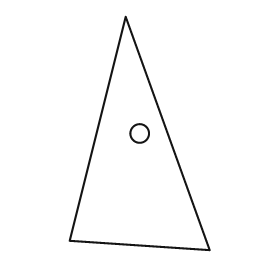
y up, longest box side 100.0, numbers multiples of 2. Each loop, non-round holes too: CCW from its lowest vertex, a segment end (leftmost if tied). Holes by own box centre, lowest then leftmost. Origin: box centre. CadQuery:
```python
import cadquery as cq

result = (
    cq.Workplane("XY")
    .moveTo(30.0, -50.0)
    .lineTo(-6.0, 50.0)
    .lineTo(-30.0, -46.0)
    .close()
    .moveTo(0.0, 0.0)
    .circle(4.0)
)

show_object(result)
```